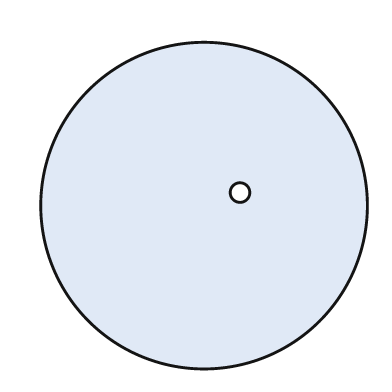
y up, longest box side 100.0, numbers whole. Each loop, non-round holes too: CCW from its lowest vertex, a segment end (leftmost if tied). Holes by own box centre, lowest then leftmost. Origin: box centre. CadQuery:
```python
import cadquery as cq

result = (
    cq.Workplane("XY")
    .moveTo(0.0, 0.0)
    .circle(50.0)
    .moveTo(11.0, 4.0)
    .circle(3.0)
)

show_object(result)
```